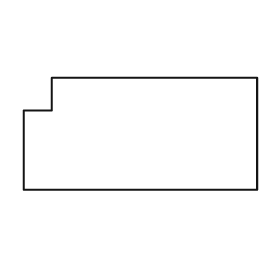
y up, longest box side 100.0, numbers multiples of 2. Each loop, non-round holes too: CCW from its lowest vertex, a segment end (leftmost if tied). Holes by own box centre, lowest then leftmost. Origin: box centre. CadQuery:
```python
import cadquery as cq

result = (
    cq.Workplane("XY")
    .moveTo(-50.0, -24.0)
    .lineTo(50.0, -24.0)
    .lineTo(50.0, 24.0)
    .lineTo(-38.0, 24.0)
    .lineTo(-38.0, 10.0)
    .lineTo(-50.0, 10.0)
    .close()
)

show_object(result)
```